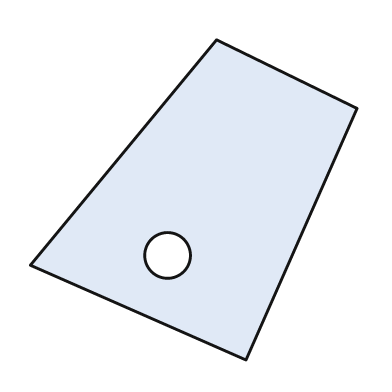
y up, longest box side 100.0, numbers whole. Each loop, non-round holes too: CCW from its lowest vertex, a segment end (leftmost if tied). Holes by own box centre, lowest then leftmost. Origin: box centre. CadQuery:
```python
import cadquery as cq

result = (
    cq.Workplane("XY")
    .moveTo(16.0, -49.0)
    .lineTo(50.0, 28.0)
    .lineTo(7.0, 49.0)
    .lineTo(-50.0, -20.0)
    .close()
    .moveTo(-8.0, -17.0)
    .circle(7.0)
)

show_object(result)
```